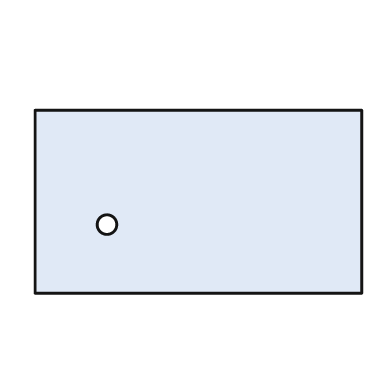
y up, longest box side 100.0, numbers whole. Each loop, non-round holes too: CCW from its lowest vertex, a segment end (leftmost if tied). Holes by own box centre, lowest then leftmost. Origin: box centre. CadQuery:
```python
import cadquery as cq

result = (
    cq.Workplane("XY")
    .moveTo(-50.0, -28.0)
    .lineTo(50.0, -28.0)
    .lineTo(50.0, 28.0)
    .lineTo(-50.0, 28.0)
    .close()
    .moveTo(-28.0, -7.0)
    .circle(3.0)
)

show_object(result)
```